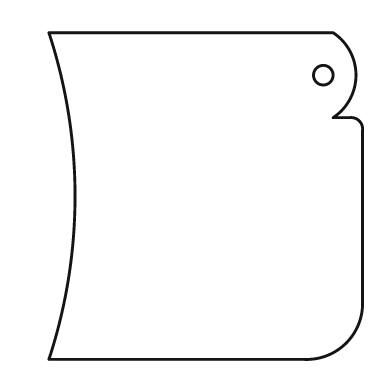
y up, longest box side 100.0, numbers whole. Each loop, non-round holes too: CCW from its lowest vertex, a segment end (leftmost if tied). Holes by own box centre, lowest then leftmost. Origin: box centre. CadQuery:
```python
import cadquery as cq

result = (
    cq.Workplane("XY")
    .moveTo(-48.0, -50.0)
    .lineTo(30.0, -50.0)
    .threePointArc((43.0, -45.0), (48.0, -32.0))
    .lineTo(48.0, 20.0)
    .threePointArc((47.0, 23.0), (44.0, 24.0))
    .lineTo(39.0, 24.0)
    .threePointArc((46.0, 37.0), (39.0, 50.0))
    .lineTo(-48.0, 50.0)
    .threePointArc((-40.0, 0.0), (-48.0, -50.0))
    .close()
    .moveTo(36.0, 37.0)
    .circle(3.0)
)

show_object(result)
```